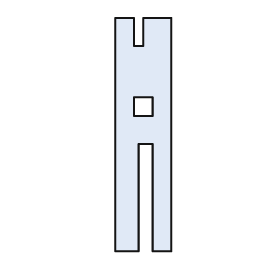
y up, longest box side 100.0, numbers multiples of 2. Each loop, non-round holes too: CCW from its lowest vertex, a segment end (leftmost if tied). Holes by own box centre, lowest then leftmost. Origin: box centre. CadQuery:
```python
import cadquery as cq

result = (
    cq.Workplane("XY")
    .moveTo(-12.0, -50.0)
    .lineTo(-2.0, -50.0)
    .lineTo(-2.0, -4.0)
    .lineTo(4.0, -4.0)
    .lineTo(4.0, -50.0)
    .lineTo(12.0, -50.0)
    .lineTo(12.0, 50.0)
    .lineTo(0.0, 50.0)
    .lineTo(0.0, 38.0)
    .lineTo(-4.0, 38.0)
    .lineTo(-4.0, 50.0)
    .lineTo(-12.0, 50.0)
    .close()
    .moveTo(-4.0, 8.0)
    .lineTo(4.0, 8.0)
    .lineTo(4.0, 16.0)
    .lineTo(-4.0, 16.0)
    .close()
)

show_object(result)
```